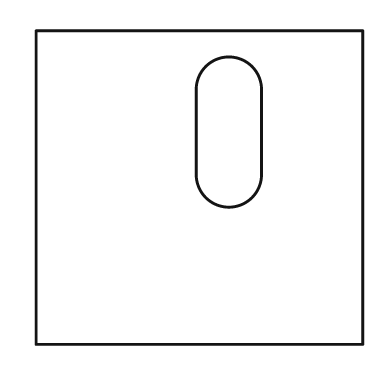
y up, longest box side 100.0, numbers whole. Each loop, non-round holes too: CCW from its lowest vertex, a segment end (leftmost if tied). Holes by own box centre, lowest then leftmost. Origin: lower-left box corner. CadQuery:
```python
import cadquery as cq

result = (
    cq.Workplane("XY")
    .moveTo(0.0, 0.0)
    .lineTo(100.0, 0.0)
    .lineTo(100.0, 96.0)
    .lineTo(0.0, 96.0)
    .close()
    .moveTo(49.0, 52.0)
    .threePointArc((59.0, 42.0), (69.0, 52.0))
    .lineTo(69.0, 78.0)
    .threePointArc((59.0, 88.0), (49.0, 78.0))
    .close()
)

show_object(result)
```